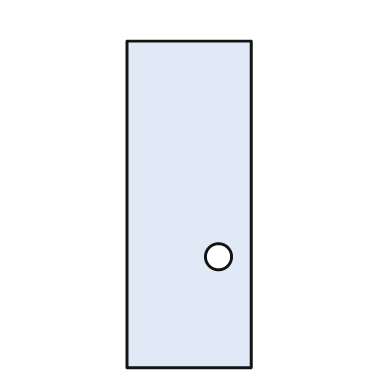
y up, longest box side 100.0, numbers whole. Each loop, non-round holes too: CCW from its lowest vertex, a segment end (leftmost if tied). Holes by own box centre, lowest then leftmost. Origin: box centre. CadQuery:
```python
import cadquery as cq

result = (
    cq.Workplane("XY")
    .moveTo(-19.0, -50.0)
    .lineTo(19.0, -50.0)
    .lineTo(19.0, 50.0)
    .lineTo(-19.0, 50.0)
    .close()
    .moveTo(9.0, -16.0)
    .circle(4.0)
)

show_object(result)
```